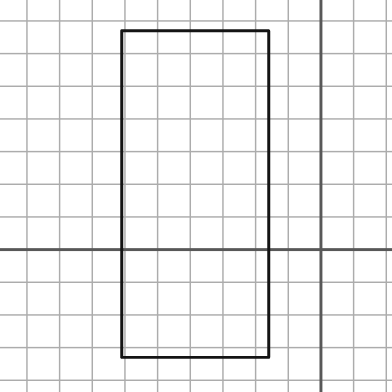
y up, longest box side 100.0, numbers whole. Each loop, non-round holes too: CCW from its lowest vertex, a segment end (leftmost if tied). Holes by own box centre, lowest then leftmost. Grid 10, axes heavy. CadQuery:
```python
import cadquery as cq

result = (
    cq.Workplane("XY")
    .moveTo(-61.0, -33.0)
    .lineTo(-16.0, -33.0)
    .lineTo(-16.0, 67.0)
    .lineTo(-61.0, 67.0)
    .close()
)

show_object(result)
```